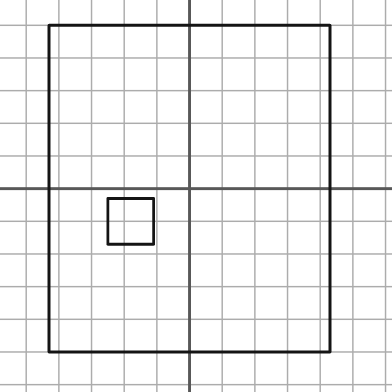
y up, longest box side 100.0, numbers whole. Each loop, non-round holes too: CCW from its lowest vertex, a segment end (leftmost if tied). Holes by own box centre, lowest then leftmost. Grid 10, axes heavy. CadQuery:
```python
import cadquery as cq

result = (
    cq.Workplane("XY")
    .moveTo(-43.0, -50.0)
    .lineTo(43.0, -50.0)
    .lineTo(43.0, 50.0)
    .lineTo(-43.0, 50.0)
    .close()
    .moveTo(-25.0, -17.0)
    .lineTo(-11.0, -17.0)
    .lineTo(-11.0, -3.0)
    .lineTo(-25.0, -3.0)
    .close()
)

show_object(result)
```